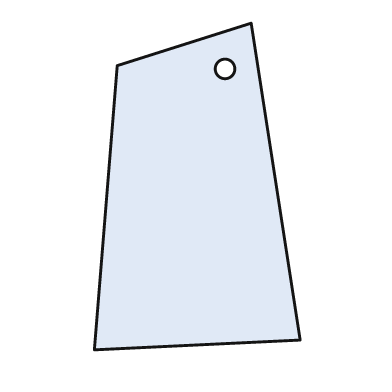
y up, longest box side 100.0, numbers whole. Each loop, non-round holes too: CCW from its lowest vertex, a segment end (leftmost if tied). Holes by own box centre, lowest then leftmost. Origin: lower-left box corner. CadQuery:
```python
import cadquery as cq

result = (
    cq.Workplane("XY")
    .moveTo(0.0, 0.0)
    .lineTo(63.0, 3.0)
    .lineTo(48.0, 100.0)
    .lineTo(7.0, 87.0)
    .close()
    .moveTo(40.0, 86.0)
    .circle(3.0)
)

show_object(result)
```